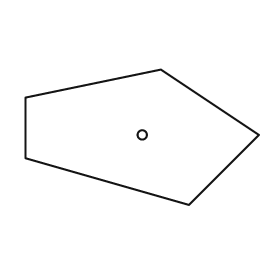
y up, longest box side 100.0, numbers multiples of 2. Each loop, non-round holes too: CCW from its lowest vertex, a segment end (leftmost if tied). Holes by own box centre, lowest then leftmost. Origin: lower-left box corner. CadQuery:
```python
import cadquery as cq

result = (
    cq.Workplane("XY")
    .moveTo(70.0, 0.0)
    .lineTo(100.0, 30.0)
    .lineTo(58.0, 58.0)
    .lineTo(0.0, 46.0)
    .lineTo(0.0, 20.0)
    .close()
    .moveTo(50.0, 30.0)
    .circle(2.0)
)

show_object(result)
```